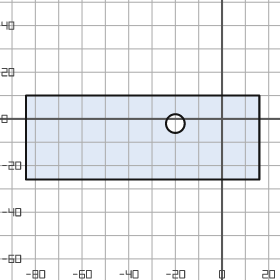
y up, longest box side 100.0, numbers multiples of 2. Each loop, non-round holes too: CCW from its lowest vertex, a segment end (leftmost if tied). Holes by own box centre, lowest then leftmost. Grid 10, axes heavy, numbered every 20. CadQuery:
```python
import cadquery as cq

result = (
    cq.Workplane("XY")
    .moveTo(-84.0, -26.0)
    .lineTo(16.0, -26.0)
    .lineTo(16.0, 10.0)
    .lineTo(-84.0, 10.0)
    .close()
    .moveTo(-20.0, -2.0)
    .circle(4.0)
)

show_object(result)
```